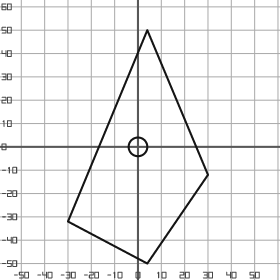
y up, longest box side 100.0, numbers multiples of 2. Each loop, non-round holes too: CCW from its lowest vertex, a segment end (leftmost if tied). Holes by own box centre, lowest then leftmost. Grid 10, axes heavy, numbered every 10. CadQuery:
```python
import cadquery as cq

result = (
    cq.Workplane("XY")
    .moveTo(4.0, -50.0)
    .lineTo(30.0, -12.0)
    .lineTo(4.0, 50.0)
    .lineTo(-30.0, -32.0)
    .close()
    .moveTo(0.0, 0.0)
    .circle(4.0)
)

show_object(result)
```